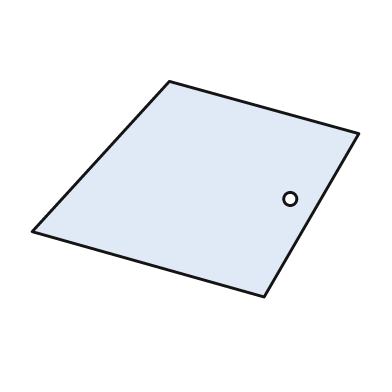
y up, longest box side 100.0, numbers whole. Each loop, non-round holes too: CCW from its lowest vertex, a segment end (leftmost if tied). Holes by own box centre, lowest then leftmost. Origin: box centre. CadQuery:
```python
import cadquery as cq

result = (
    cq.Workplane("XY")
    .moveTo(21.0, -33.0)
    .lineTo(50.0, 17.0)
    .lineTo(-8.0, 33.0)
    .lineTo(-50.0, -13.0)
    .close()
    .moveTo(29.0, -3.0)
    .circle(2.0)
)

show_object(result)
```